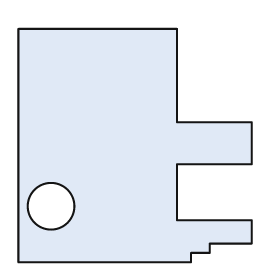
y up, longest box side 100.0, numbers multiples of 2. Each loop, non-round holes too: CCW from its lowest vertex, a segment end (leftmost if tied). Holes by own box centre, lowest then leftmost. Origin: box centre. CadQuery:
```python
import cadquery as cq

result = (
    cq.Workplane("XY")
    .moveTo(-50.0, -50.0)
    .lineTo(24.0, -50.0)
    .lineTo(24.0, -46.0)
    .lineTo(32.0, -46.0)
    .lineTo(32.0, -42.0)
    .lineTo(50.0, -42.0)
    .lineTo(50.0, -32.0)
    .lineTo(18.0, -32.0)
    .lineTo(18.0, -8.0)
    .lineTo(50.0, -8.0)
    .lineTo(50.0, 10.0)
    .lineTo(18.0, 10.0)
    .lineTo(18.0, 50.0)
    .lineTo(-50.0, 50.0)
    .close()
    .moveTo(-36.0, -26.0)
    .circle(10.0)
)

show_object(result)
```